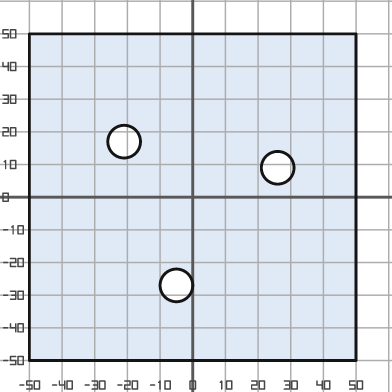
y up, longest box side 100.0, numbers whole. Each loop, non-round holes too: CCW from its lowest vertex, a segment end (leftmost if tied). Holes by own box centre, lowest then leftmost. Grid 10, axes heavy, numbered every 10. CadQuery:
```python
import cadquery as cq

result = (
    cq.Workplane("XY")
    .moveTo(-50.0, -50.0)
    .lineTo(50.0, -50.0)
    .lineTo(50.0, 50.0)
    .lineTo(-50.0, 50.0)
    .close()
    .moveTo(-5.0, -27.0)
    .circle(5.0)
    .moveTo(26.0, 9.0)
    .circle(5.0)
    .moveTo(-21.0, 17.0)
    .circle(5.0)
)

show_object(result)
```